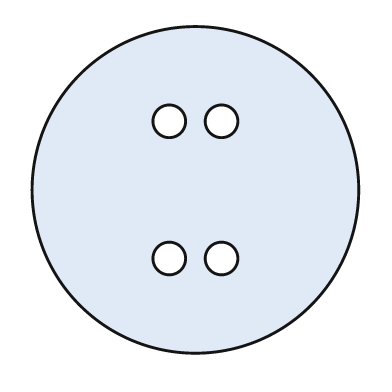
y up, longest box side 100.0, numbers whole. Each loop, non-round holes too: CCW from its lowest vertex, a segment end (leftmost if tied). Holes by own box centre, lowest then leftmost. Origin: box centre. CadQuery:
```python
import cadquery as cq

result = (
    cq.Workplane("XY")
    .moveTo(0.0, 0.0)
    .circle(50.0)
    .moveTo(-8.0, -21.0)
    .circle(5.0)
    .moveTo(8.0, -21.0)
    .circle(5.0)
    .moveTo(-8.0, 21.0)
    .circle(5.0)
    .moveTo(8.0, 21.0)
    .circle(5.0)
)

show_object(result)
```